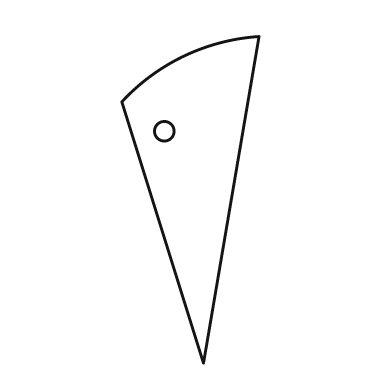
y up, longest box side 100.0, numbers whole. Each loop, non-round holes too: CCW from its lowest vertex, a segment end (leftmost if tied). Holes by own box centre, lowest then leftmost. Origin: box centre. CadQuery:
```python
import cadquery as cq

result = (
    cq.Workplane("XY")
    .moveTo(4.0, -50.0)
    .lineTo(21.0, 50.0)
    .threePointArc((-2.0, 44.0), (-21.0, 30.0))
    .close()
    .moveTo(-8.0, 21.0)
    .circle(3.0)
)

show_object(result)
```